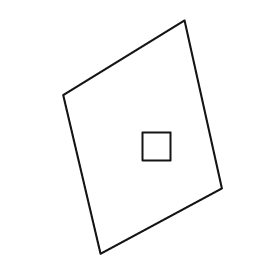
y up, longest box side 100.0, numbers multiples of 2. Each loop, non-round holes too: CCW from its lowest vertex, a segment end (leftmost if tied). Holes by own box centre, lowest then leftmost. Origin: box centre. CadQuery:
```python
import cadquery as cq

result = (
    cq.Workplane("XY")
    .moveTo(-18.0, -50.0)
    .lineTo(34.0, -22.0)
    .lineTo(18.0, 50.0)
    .lineTo(-34.0, 18.0)
    .close()
    .moveTo(0.0, -10.0)
    .lineTo(12.0, -10.0)
    .lineTo(12.0, 2.0)
    .lineTo(0.0, 2.0)
    .close()
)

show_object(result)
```